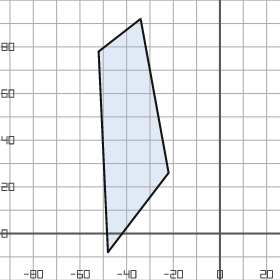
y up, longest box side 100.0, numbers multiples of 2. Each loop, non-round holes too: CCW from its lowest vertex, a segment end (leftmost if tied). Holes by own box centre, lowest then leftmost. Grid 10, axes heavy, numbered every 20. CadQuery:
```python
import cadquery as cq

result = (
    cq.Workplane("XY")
    .moveTo(-48.0, -8.0)
    .lineTo(-22.0, 26.0)
    .lineTo(-34.0, 92.0)
    .lineTo(-52.0, 78.0)
    .close()
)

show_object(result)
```